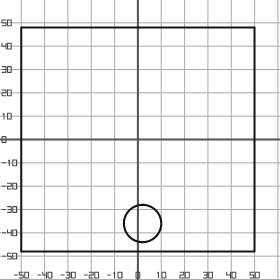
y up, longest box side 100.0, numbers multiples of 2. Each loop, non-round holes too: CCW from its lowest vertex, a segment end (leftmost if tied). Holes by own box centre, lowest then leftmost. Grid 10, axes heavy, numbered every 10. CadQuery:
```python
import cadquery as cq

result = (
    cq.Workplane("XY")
    .moveTo(-50.0, -48.0)
    .lineTo(50.0, -48.0)
    .lineTo(50.0, 48.0)
    .lineTo(-50.0, 48.0)
    .close()
    .moveTo(2.0, -36.0)
    .circle(8.0)
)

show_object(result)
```